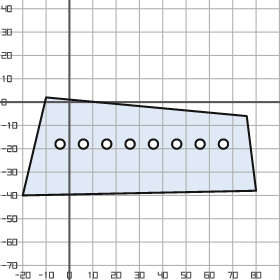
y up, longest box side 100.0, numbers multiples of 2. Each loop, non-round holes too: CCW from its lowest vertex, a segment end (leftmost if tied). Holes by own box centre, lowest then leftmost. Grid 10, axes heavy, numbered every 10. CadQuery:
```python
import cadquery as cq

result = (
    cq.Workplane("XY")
    .moveTo(-20.0, -40.0)
    .lineTo(80.0, -38.0)
    .lineTo(76.0, -6.0)
    .lineTo(-10.0, 2.0)
    .close()
    .moveTo(-4.0, -18.0)
    .circle(2.0)
    .moveTo(6.0, -18.0)
    .circle(2.0)
    .moveTo(16.0, -18.0)
    .circle(2.0)
    .moveTo(26.0, -18.0)
    .circle(2.0)
    .moveTo(36.0, -18.0)
    .circle(2.0)
    .moveTo(46.0, -18.0)
    .circle(2.0)
    .moveTo(56.0, -18.0)
    .circle(2.0)
    .moveTo(66.0, -18.0)
    .circle(2.0)
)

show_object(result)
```